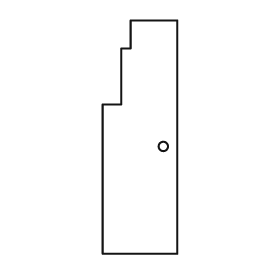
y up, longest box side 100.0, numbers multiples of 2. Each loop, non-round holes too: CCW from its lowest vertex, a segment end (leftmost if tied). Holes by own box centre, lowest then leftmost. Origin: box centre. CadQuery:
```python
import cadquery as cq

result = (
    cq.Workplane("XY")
    .moveTo(-16.0, -50.0)
    .lineTo(16.0, -50.0)
    .lineTo(16.0, 50.0)
    .lineTo(-4.0, 50.0)
    .lineTo(-4.0, 38.0)
    .lineTo(-8.0, 38.0)
    .lineTo(-8.0, 14.0)
    .lineTo(-16.0, 14.0)
    .close()
    .moveTo(10.0, -4.0)
    .circle(2.0)
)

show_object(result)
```